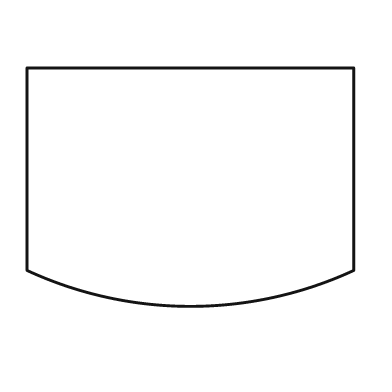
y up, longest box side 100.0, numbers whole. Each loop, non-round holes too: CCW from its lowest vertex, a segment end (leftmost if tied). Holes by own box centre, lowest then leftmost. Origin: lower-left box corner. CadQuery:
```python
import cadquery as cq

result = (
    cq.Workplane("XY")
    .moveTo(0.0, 11.0)
    .threePointArc((50.0, 0.0), (100.0, 11.0))
    .lineTo(100.0, 73.0)
    .lineTo(0.0, 73.0)
    .close()
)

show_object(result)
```